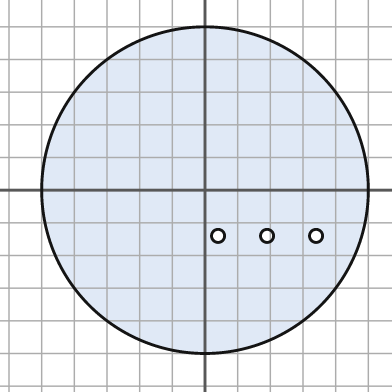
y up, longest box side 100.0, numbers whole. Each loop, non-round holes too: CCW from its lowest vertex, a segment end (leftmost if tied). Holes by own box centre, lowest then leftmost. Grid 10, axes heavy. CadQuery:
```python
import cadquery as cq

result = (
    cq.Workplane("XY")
    .moveTo(0.0, 0.0)
    .circle(50.0)
    .moveTo(4.0, -14.0)
    .circle(2.0)
    .moveTo(19.0, -14.0)
    .circle(2.0)
    .moveTo(34.0, -14.0)
    .circle(2.0)
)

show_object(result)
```